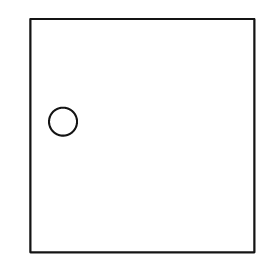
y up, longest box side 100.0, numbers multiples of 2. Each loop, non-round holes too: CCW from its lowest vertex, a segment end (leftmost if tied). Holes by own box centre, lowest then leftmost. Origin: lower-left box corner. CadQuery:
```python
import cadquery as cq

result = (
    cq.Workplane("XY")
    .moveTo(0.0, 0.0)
    .lineTo(96.0, 0.0)
    .lineTo(96.0, 100.0)
    .lineTo(0.0, 100.0)
    .close()
    .moveTo(14.0, 56.0)
    .circle(6.0)
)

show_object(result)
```